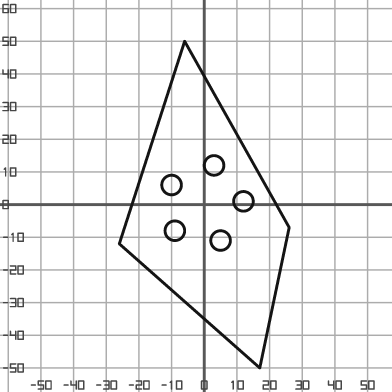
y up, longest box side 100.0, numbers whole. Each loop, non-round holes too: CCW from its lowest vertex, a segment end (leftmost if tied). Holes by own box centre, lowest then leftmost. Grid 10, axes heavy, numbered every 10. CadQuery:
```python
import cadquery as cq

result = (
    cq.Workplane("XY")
    .moveTo(17.0, -50.0)
    .lineTo(26.0, -7.0)
    .lineTo(-6.0, 50.0)
    .lineTo(-26.0, -12.0)
    .close()
    .moveTo(5.0, -11.0)
    .circle(3.0)
    .moveTo(-9.0, -8.0)
    .circle(3.0)
    .moveTo(12.0, 1.0)
    .circle(3.0)
    .moveTo(-10.0, 6.0)
    .circle(3.0)
    .moveTo(3.0, 12.0)
    .circle(3.0)
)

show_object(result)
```